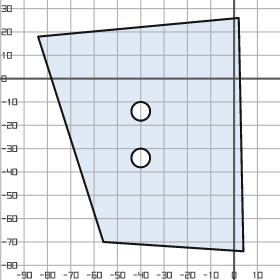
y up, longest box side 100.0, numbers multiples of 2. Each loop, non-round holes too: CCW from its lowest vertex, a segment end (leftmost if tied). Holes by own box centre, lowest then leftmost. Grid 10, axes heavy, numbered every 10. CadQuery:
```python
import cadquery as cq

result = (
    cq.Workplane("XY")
    .moveTo(4.0, -74.0)
    .lineTo(2.0, 26.0)
    .lineTo(-84.0, 18.0)
    .lineTo(-56.0, -70.0)
    .close()
    .moveTo(-40.0, -34.0)
    .circle(4.0)
    .moveTo(-40.0, -14.0)
    .circle(4.0)
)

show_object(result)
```